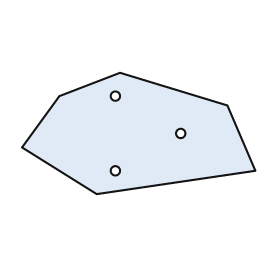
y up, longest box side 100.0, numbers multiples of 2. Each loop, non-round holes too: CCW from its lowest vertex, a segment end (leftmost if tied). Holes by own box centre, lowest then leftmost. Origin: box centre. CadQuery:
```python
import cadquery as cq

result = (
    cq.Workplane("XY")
    .moveTo(-18.0, -26.0)
    .lineTo(50.0, -16.0)
    .lineTo(38.0, 12.0)
    .lineTo(-8.0, 26.0)
    .lineTo(-34.0, 16.0)
    .lineTo(-50.0, -6.0)
    .close()
    .moveTo(-10.0, -16.0)
    .circle(2.0)
    .moveTo(18.0, 0.0)
    .circle(2.0)
    .moveTo(-10.0, 16.0)
    .circle(2.0)
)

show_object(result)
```